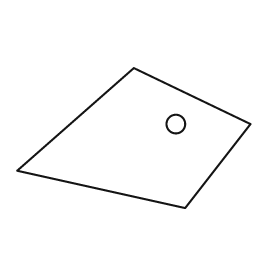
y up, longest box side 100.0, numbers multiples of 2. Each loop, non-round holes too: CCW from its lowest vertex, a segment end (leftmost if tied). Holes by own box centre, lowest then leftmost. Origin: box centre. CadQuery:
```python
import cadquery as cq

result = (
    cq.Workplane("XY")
    .moveTo(22.0, -30.0)
    .lineTo(50.0, 6.0)
    .lineTo(0.0, 30.0)
    .lineTo(-50.0, -14.0)
    .close()
    .moveTo(18.0, 6.0)
    .circle(4.0)
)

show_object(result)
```